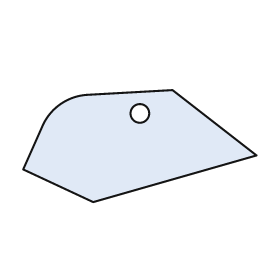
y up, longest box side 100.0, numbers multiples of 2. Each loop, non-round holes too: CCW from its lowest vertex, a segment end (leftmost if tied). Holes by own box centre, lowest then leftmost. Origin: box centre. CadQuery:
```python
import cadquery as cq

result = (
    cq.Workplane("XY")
    .moveTo(-20.0, -24.0)
    .lineTo(50.0, -4.0)
    .lineTo(14.0, 24.0)
    .lineTo(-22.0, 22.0)
    .threePointArc((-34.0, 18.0), (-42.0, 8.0))
    .lineTo(-50.0, -10.0)
    .close()
    .moveTo(0.0, 14.0)
    .circle(4.0)
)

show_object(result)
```